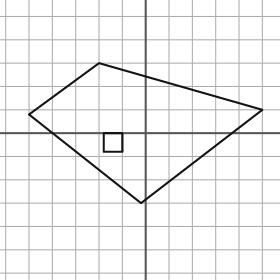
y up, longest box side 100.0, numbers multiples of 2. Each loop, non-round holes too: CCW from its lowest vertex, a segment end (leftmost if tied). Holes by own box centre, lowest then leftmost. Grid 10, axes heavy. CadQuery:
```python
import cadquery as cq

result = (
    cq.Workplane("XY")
    .moveTo(-2.0, -30.0)
    .lineTo(50.0, 10.0)
    .lineTo(-20.0, 30.0)
    .lineTo(-50.0, 8.0)
    .close()
    .moveTo(-18.0, -8.0)
    .lineTo(-10.0, -8.0)
    .lineTo(-10.0, 0.0)
    .lineTo(-18.0, 0.0)
    .close()
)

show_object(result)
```